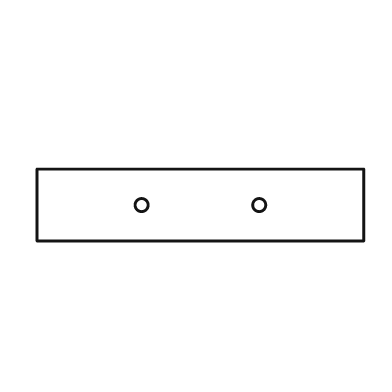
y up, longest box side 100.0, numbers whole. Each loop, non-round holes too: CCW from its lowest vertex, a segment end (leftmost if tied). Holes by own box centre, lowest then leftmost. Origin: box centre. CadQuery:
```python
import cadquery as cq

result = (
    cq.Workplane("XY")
    .moveTo(-50.0, -11.0)
    .lineTo(50.0, -11.0)
    .lineTo(50.0, 11.0)
    .lineTo(-50.0, 11.0)
    .close()
    .moveTo(-18.0, 0.0)
    .circle(2.0)
    .moveTo(18.0, 0.0)
    .circle(2.0)
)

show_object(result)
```